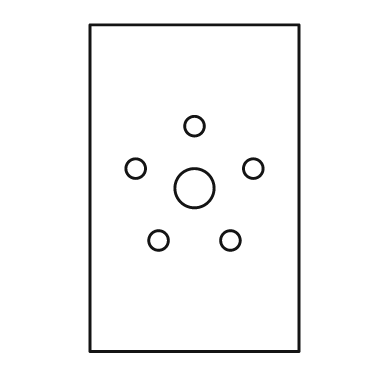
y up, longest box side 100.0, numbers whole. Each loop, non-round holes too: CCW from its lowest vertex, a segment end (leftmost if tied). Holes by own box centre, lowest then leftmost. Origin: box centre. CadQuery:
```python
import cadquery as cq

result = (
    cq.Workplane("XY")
    .moveTo(-32.0, -50.0)
    .lineTo(32.0, -50.0)
    .lineTo(32.0, 50.0)
    .lineTo(-32.0, 50.0)
    .close()
    .moveTo(-11.0, -16.0)
    .circle(3.0)
    .moveTo(11.0, -16.0)
    .circle(3.0)
    .moveTo(0.0, 0.0)
    .circle(6.0)
    .moveTo(-18.0, 6.0)
    .circle(3.0)
    .moveTo(18.0, 6.0)
    .circle(3.0)
    .moveTo(0.0, 19.0)
    .circle(3.0)
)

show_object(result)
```